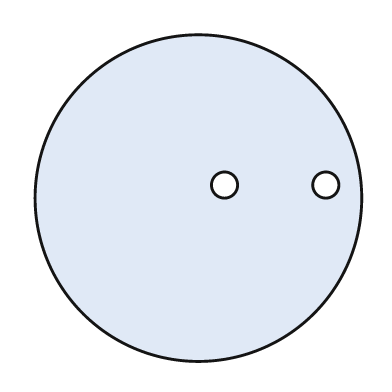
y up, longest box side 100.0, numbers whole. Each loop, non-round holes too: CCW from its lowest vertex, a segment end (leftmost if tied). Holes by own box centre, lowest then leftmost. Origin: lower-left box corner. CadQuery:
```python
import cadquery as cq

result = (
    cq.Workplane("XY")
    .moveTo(50.0, 50.0)
    .circle(50.0)
    .moveTo(58.0, 54.0)
    .circle(4.0)
    .moveTo(89.0, 54.0)
    .circle(4.0)
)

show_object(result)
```